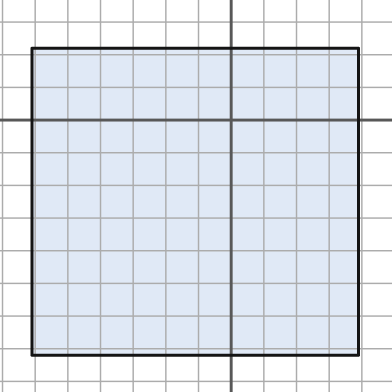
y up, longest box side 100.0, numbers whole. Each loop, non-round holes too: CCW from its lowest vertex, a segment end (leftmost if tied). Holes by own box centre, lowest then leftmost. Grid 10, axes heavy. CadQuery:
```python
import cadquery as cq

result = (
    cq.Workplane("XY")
    .moveTo(-61.0, -72.0)
    .lineTo(39.0, -72.0)
    .lineTo(39.0, 22.0)
    .lineTo(-61.0, 22.0)
    .close()
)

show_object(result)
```